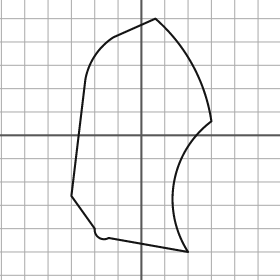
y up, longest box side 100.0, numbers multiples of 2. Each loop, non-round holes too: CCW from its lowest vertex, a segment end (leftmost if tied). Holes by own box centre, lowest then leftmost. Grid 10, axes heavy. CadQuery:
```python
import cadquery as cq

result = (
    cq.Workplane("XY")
    .moveTo(20.0, -50.0)
    .threePointArc((14.0, -20.0), (30.0, 6.0))
    .threePointArc((22.0, 30.0), (6.0, 50.0))
    .lineTo(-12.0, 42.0)
    .threePointArc((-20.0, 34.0), (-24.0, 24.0))
    .lineTo(-30.0, -26.0)
    .lineTo(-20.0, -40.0)
    .threePointArc((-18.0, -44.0), (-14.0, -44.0))
    .close()
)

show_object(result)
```